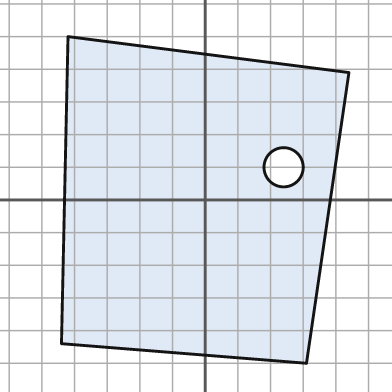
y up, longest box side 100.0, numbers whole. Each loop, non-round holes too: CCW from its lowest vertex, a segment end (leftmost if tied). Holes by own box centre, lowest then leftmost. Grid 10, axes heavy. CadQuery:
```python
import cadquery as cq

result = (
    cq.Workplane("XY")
    .moveTo(31.0, -50.0)
    .lineTo(44.0, 39.0)
    .lineTo(-42.0, 50.0)
    .lineTo(-44.0, -44.0)
    .close()
    .moveTo(24.0, 10.0)
    .circle(6.0)
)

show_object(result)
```